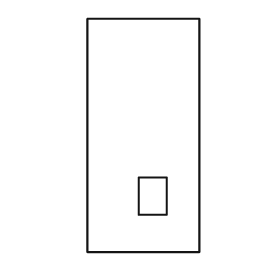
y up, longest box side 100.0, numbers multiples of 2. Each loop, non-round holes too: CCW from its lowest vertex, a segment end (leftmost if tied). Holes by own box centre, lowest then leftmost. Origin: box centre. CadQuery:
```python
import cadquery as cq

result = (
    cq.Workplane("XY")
    .moveTo(-24.0, -50.0)
    .lineTo(24.0, -50.0)
    .lineTo(24.0, 50.0)
    .lineTo(-24.0, 50.0)
    .close()
    .moveTo(-2.0, -34.0)
    .lineTo(10.0, -34.0)
    .lineTo(10.0, -18.0)
    .lineTo(-2.0, -18.0)
    .close()
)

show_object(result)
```